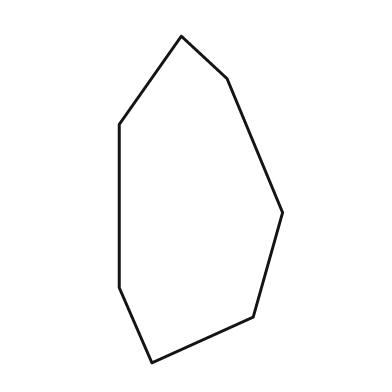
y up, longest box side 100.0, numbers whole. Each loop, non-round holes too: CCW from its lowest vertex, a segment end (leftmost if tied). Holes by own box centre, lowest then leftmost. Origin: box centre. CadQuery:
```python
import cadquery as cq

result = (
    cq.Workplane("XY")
    .moveTo(-15.0, -50.0)
    .lineTo(16.0, -36.0)
    .lineTo(25.0, -4.0)
    .lineTo(8.0, 37.0)
    .lineTo(-6.0, 50.0)
    .lineTo(-25.0, 23.0)
    .lineTo(-25.0, -27.0)
    .close()
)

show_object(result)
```